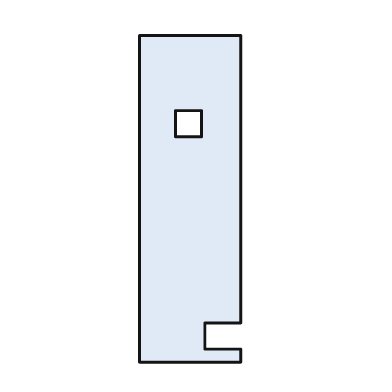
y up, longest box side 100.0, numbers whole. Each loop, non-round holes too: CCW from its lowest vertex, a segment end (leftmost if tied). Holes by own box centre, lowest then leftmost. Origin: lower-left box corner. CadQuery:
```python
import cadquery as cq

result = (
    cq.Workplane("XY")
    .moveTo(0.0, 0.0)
    .lineTo(31.0, 0.0)
    .lineTo(31.0, 4.0)
    .lineTo(20.0, 4.0)
    .lineTo(20.0, 12.0)
    .lineTo(31.0, 12.0)
    .lineTo(31.0, 100.0)
    .lineTo(0.0, 100.0)
    .close()
    .moveTo(11.0, 69.0)
    .lineTo(19.0, 69.0)
    .lineTo(19.0, 77.0)
    .lineTo(11.0, 77.0)
    .close()
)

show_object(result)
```